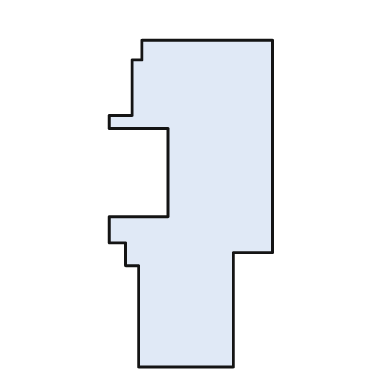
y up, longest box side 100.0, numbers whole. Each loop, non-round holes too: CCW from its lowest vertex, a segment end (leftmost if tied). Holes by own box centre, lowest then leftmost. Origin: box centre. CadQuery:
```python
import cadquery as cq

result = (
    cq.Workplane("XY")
    .moveTo(-16.0, -50.0)
    .lineTo(13.0, -50.0)
    .lineTo(13.0, -15.0)
    .lineTo(25.0, -15.0)
    .lineTo(25.0, 50.0)
    .lineTo(-15.0, 50.0)
    .lineTo(-15.0, 44.0)
    .lineTo(-18.0, 44.0)
    .lineTo(-18.0, 27.0)
    .lineTo(-25.0, 27.0)
    .lineTo(-25.0, 23.0)
    .lineTo(-7.0, 23.0)
    .lineTo(-7.0, -4.0)
    .lineTo(-25.0, -4.0)
    .lineTo(-25.0, -12.0)
    .lineTo(-20.0, -12.0)
    .lineTo(-20.0, -19.0)
    .lineTo(-16.0, -19.0)
    .close()
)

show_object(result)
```